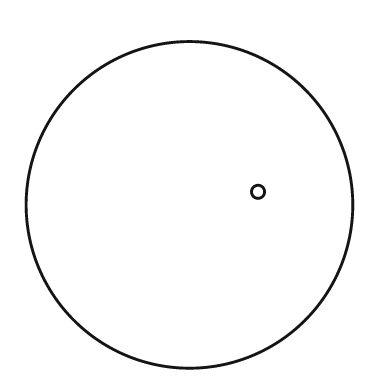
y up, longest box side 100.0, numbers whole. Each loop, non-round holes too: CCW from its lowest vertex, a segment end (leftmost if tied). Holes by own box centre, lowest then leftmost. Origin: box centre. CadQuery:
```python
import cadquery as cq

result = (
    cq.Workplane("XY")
    .moveTo(0.0, 0.0)
    .circle(50.0)
    .moveTo(21.0, 4.0)
    .circle(2.0)
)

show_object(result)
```